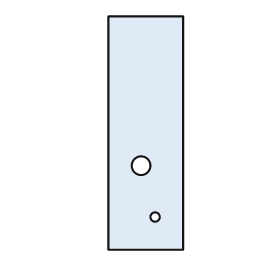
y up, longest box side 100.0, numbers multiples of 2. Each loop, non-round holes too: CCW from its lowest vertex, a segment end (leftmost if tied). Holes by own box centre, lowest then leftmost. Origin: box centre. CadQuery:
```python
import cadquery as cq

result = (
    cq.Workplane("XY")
    .moveTo(-16.0, -50.0)
    .lineTo(16.0, -50.0)
    .lineTo(16.0, 50.0)
    .lineTo(-16.0, 50.0)
    .close()
    .moveTo(4.0, -36.0)
    .circle(2.0)
    .moveTo(-2.0, -14.0)
    .circle(4.0)
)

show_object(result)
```